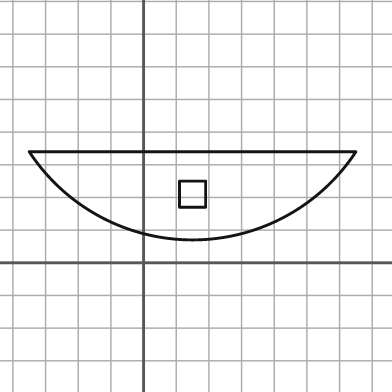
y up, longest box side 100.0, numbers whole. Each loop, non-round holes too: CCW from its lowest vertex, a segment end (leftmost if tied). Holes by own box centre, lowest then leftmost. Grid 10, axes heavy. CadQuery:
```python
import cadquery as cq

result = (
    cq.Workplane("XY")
    .moveTo(-35.0, 34.0)
    .threePointArc((15.0, 7.0), (65.0, 34.0))
    .close()
    .moveTo(11.0, 17.0)
    .lineTo(19.0, 17.0)
    .lineTo(19.0, 25.0)
    .lineTo(11.0, 25.0)
    .close()
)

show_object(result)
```